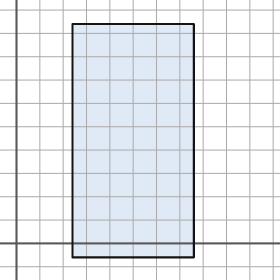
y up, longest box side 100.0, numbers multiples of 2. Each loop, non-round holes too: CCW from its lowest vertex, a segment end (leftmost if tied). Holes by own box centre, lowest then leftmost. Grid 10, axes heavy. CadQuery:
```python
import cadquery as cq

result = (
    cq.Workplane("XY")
    .moveTo(24.0, -6.0)
    .lineTo(76.0, -6.0)
    .lineTo(76.0, 94.0)
    .lineTo(24.0, 94.0)
    .close()
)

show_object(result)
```